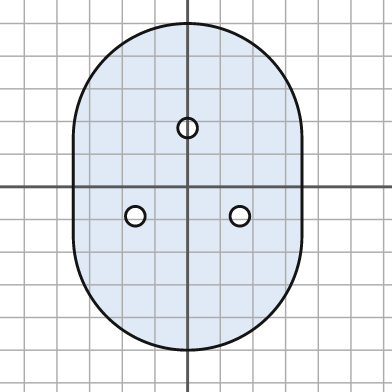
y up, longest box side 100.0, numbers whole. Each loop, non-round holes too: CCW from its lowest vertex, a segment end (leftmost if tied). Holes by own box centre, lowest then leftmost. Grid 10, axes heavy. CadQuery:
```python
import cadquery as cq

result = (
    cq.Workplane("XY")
    .moveTo(-35.0, -15.0)
    .threePointArc((0.0, -50.0), (35.0, -15.0))
    .lineTo(35.0, 15.0)
    .threePointArc((0.0, 50.0), (-35.0, 15.0))
    .close()
    .moveTo(-16.0, -9.0)
    .circle(3.0)
    .moveTo(16.0, -9.0)
    .circle(3.0)
    .moveTo(0.0, 18.0)
    .circle(3.0)
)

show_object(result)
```